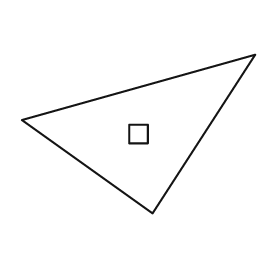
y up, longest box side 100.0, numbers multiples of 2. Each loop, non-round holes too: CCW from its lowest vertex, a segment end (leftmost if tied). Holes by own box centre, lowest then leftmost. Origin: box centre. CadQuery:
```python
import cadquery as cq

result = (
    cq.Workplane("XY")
    .moveTo(6.0, -34.0)
    .lineTo(50.0, 34.0)
    .lineTo(-50.0, 6.0)
    .close()
    .moveTo(-4.0, -4.0)
    .lineTo(4.0, -4.0)
    .lineTo(4.0, 4.0)
    .lineTo(-4.0, 4.0)
    .close()
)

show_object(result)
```